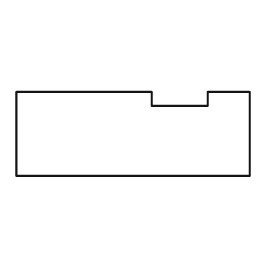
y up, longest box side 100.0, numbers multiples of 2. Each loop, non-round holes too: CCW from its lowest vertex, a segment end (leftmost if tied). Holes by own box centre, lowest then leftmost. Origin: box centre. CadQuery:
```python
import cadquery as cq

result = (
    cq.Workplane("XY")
    .moveTo(-50.0, -18.0)
    .lineTo(50.0, -18.0)
    .lineTo(50.0, 18.0)
    .lineTo(32.0, 18.0)
    .lineTo(32.0, 12.0)
    .lineTo(8.0, 12.0)
    .lineTo(8.0, 18.0)
    .lineTo(-50.0, 18.0)
    .close()
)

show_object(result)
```